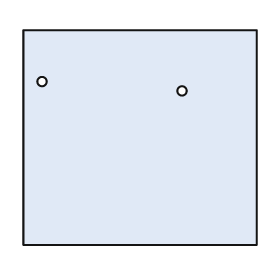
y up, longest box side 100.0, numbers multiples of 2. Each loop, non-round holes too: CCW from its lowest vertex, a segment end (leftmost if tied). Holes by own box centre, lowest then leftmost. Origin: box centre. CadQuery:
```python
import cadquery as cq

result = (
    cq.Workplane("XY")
    .moveTo(-50.0, -46.0)
    .lineTo(50.0, -46.0)
    .lineTo(50.0, 46.0)
    .lineTo(-50.0, 46.0)
    .close()
    .moveTo(18.0, 20.0)
    .circle(2.0)
    .moveTo(-42.0, 24.0)
    .circle(2.0)
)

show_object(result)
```